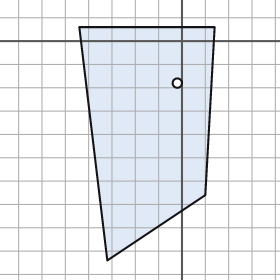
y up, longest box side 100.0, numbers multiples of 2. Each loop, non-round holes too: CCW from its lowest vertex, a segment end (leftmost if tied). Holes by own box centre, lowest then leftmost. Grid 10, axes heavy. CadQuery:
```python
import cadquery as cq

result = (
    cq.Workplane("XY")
    .moveTo(-32.0, -94.0)
    .lineTo(10.0, -66.0)
    .lineTo(14.0, 6.0)
    .lineTo(-44.0, 6.0)
    .close()
    .moveTo(-2.0, -18.0)
    .circle(2.0)
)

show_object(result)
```